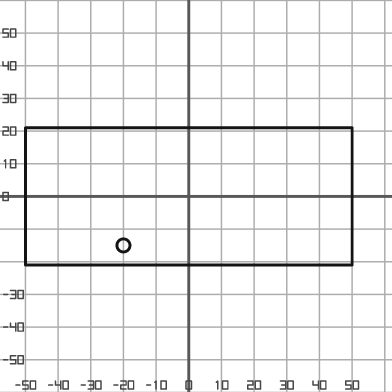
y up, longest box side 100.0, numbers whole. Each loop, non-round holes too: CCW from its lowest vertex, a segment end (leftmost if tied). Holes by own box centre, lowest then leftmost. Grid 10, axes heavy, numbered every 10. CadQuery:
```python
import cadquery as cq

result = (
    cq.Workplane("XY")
    .moveTo(-50.0, -21.0)
    .lineTo(50.0, -21.0)
    .lineTo(50.0, 21.0)
    .lineTo(-50.0, 21.0)
    .close()
    .moveTo(-20.0, -15.0)
    .circle(2.0)
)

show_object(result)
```